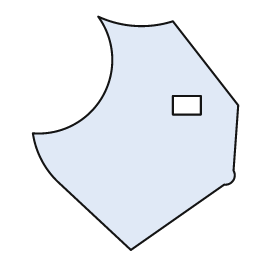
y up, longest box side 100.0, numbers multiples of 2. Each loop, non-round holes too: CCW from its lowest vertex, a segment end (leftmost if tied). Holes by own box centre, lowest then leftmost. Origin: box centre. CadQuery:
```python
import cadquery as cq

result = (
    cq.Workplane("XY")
    .moveTo(-2.0, -50.0)
    .lineTo(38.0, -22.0)
    .threePointArc((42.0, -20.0), (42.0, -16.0))
    .lineTo(44.0, 12.0)
    .lineTo(16.0, 48.0)
    .threePointArc((0.0, 46.0), (-16.0, 50.0))
    .threePointArc((-14.0, 16.0), (-44.0, 0.0))
    .threePointArc((-40.0, -12.0), (-32.0, -22.0))
    .close()
    .moveTo(16.0, 8.0)
    .lineTo(28.0, 8.0)
    .lineTo(28.0, 16.0)
    .lineTo(16.0, 16.0)
    .close()
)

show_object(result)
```